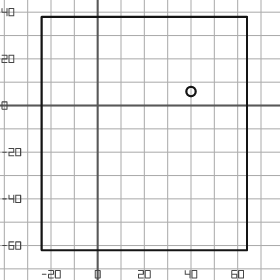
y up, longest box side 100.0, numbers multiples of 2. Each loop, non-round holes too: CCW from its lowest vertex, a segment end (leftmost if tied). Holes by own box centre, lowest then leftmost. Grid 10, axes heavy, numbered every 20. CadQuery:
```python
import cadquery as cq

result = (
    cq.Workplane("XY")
    .moveTo(-24.0, -62.0)
    .lineTo(64.0, -62.0)
    .lineTo(64.0, 38.0)
    .lineTo(-24.0, 38.0)
    .close()
    .moveTo(40.0, 6.0)
    .circle(2.0)
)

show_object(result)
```